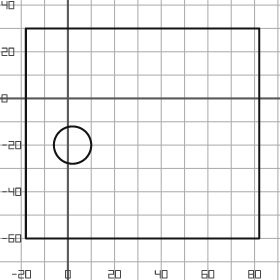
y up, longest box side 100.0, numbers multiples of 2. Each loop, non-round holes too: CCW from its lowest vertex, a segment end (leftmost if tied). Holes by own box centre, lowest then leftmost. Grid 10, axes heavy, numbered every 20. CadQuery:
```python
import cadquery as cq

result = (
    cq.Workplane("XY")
    .moveTo(-18.0, -60.0)
    .lineTo(82.0, -60.0)
    .lineTo(82.0, 30.0)
    .lineTo(-18.0, 30.0)
    .close()
    .moveTo(2.0, -20.0)
    .circle(8.0)
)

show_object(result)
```